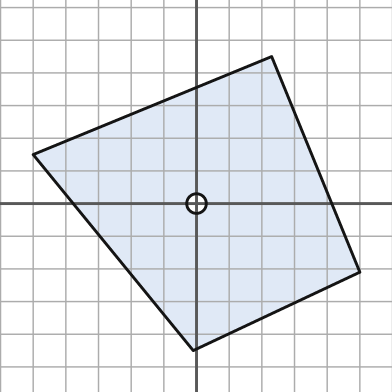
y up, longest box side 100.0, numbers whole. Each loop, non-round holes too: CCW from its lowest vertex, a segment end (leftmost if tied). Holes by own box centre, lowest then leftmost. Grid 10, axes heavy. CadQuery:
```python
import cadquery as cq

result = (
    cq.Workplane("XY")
    .moveTo(-1.0, -45.0)
    .lineTo(50.0, -21.0)
    .lineTo(23.0, 45.0)
    .lineTo(-50.0, 15.0)
    .close()
    .moveTo(0.0, 0.0)
    .circle(3.0)
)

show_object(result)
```